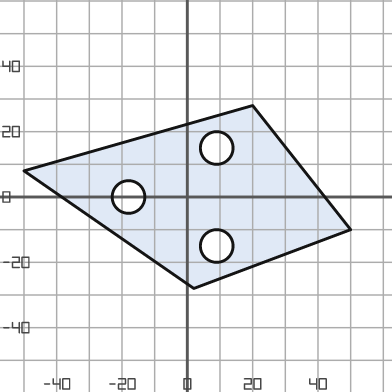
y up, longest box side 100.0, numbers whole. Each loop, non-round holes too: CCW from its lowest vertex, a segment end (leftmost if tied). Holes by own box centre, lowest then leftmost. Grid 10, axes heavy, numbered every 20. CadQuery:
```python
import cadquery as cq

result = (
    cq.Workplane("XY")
    .moveTo(2.0, -28.0)
    .lineTo(50.0, -10.0)
    .lineTo(20.0, 28.0)
    .lineTo(-50.0, 8.0)
    .close()
    .moveTo(9.0, -15.0)
    .circle(5.0)
    .moveTo(-18.0, 0.0)
    .circle(5.0)
    .moveTo(9.0, 15.0)
    .circle(5.0)
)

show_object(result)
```